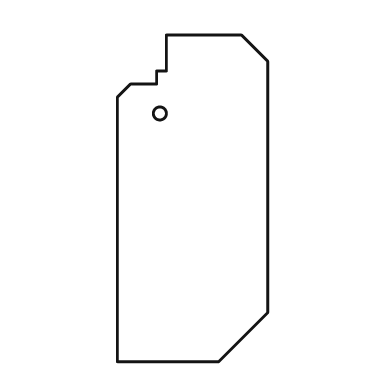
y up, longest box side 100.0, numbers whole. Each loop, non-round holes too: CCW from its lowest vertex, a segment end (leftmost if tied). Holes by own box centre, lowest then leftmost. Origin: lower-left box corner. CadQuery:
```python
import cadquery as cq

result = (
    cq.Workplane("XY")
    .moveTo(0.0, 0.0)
    .lineTo(31.0, 0.0)
    .lineTo(46.0, 15.0)
    .lineTo(46.0, 92.0)
    .lineTo(38.0, 100.0)
    .lineTo(15.0, 100.0)
    .lineTo(15.0, 89.0)
    .lineTo(12.0, 89.0)
    .lineTo(12.0, 85.0)
    .lineTo(4.0, 85.0)
    .lineTo(0.0, 81.0)
    .close()
    .moveTo(13.0, 76.0)
    .circle(2.0)
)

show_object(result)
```